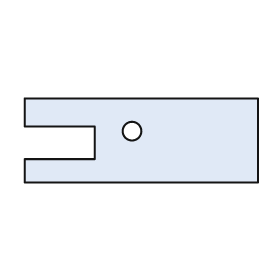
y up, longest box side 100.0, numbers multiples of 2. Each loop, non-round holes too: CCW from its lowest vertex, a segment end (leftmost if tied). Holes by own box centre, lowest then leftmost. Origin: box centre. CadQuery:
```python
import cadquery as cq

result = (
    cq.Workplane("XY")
    .moveTo(-50.0, -18.0)
    .lineTo(50.0, -18.0)
    .lineTo(50.0, 18.0)
    .lineTo(-50.0, 18.0)
    .lineTo(-50.0, 6.0)
    .lineTo(-20.0, 6.0)
    .lineTo(-20.0, -8.0)
    .lineTo(-50.0, -8.0)
    .close()
    .moveTo(-4.0, 4.0)
    .circle(4.0)
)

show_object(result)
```